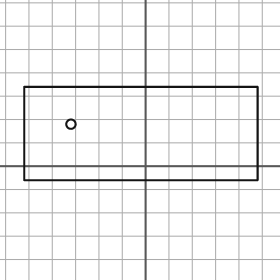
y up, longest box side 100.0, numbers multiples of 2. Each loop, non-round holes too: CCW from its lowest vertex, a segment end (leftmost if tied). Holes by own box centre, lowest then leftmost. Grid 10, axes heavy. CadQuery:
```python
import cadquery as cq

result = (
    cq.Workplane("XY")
    .moveTo(-52.0, -6.0)
    .lineTo(48.0, -6.0)
    .lineTo(48.0, 34.0)
    .lineTo(-52.0, 34.0)
    .close()
    .moveTo(-32.0, 18.0)
    .circle(2.0)
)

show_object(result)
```